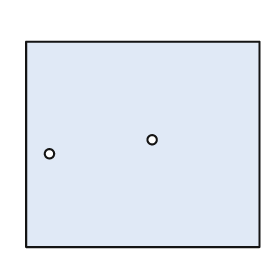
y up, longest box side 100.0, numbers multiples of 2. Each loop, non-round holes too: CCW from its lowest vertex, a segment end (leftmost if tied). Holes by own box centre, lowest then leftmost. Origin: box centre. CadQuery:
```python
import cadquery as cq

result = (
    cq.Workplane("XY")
    .moveTo(-50.0, -44.0)
    .lineTo(50.0, -44.0)
    .lineTo(50.0, 44.0)
    .lineTo(-50.0, 44.0)
    .close()
    .moveTo(-40.0, -4.0)
    .circle(2.0)
    .moveTo(4.0, 2.0)
    .circle(2.0)
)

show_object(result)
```